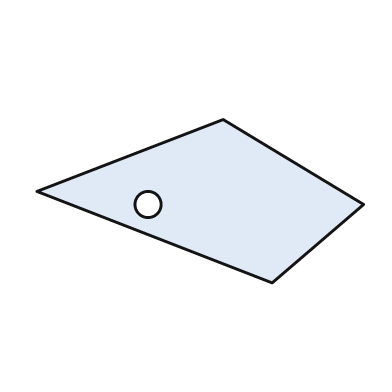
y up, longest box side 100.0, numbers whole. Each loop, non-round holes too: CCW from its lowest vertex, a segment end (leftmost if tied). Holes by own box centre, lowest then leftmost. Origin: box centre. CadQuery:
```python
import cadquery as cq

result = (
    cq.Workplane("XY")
    .moveTo(22.0, -25.0)
    .lineTo(50.0, -1.0)
    .lineTo(7.0, 25.0)
    .lineTo(-50.0, 3.0)
    .close()
    .moveTo(-16.0, -1.0)
    .circle(4.0)
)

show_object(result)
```